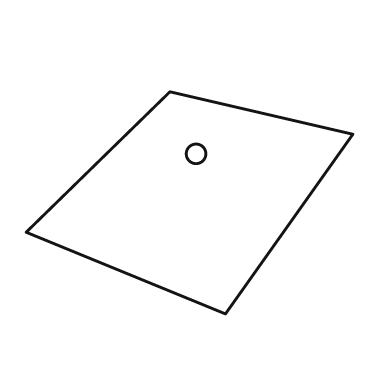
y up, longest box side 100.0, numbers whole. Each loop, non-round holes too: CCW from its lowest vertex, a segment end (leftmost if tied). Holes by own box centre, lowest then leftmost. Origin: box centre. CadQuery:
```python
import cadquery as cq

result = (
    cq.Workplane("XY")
    .moveTo(11.0, -34.0)
    .lineTo(50.0, 21.0)
    .lineTo(-6.0, 34.0)
    .lineTo(-50.0, -9.0)
    .close()
    .moveTo(2.0, 15.0)
    .circle(3.0)
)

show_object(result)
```